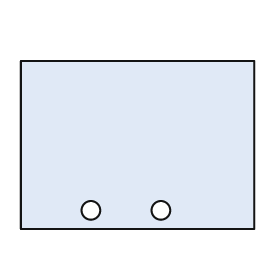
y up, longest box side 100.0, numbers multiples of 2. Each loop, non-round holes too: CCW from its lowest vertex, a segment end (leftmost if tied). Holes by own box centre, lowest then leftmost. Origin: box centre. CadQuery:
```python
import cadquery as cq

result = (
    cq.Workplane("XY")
    .moveTo(-50.0, -36.0)
    .lineTo(50.0, -36.0)
    .lineTo(50.0, 36.0)
    .lineTo(-50.0, 36.0)
    .close()
    .moveTo(-20.0, -28.0)
    .circle(4.0)
    .moveTo(10.0, -28.0)
    .circle(4.0)
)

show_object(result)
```